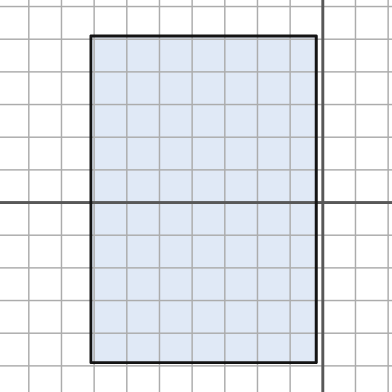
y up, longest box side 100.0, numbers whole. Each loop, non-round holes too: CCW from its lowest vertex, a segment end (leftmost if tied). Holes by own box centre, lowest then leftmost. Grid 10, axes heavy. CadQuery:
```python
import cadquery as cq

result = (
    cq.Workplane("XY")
    .moveTo(-71.0, -49.0)
    .lineTo(-2.0, -49.0)
    .lineTo(-2.0, 51.0)
    .lineTo(-71.0, 51.0)
    .close()
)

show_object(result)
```